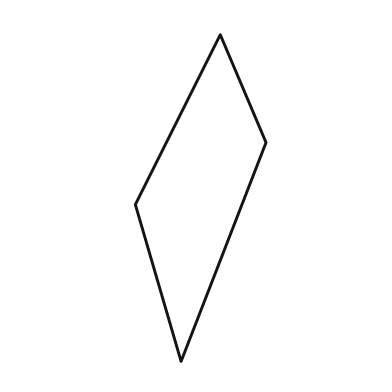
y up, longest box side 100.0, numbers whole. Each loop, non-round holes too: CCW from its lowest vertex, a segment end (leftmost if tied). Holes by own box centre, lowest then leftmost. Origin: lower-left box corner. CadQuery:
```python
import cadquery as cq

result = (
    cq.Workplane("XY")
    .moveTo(14.0, 0.0)
    .lineTo(40.0, 67.0)
    .lineTo(26.0, 100.0)
    .lineTo(0.0, 48.0)
    .close()
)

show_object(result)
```